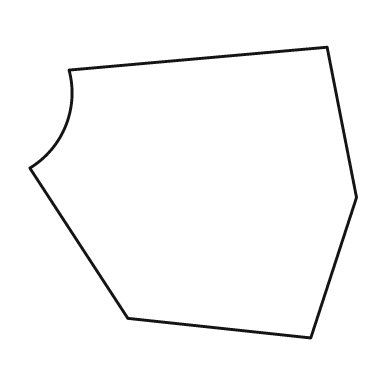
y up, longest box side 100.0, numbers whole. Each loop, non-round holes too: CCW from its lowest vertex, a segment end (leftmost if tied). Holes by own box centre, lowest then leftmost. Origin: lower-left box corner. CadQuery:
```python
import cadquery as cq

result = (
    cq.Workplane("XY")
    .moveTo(86.0, 0.0)
    .lineTo(100.0, 43.0)
    .lineTo(91.0, 89.0)
    .lineTo(12.0, 82.0)
    .threePointArc((11.0, 65.0), (0.0, 52.0))
    .lineTo(30.0, 6.0)
    .close()
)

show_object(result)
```